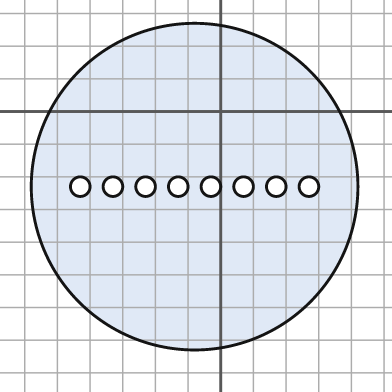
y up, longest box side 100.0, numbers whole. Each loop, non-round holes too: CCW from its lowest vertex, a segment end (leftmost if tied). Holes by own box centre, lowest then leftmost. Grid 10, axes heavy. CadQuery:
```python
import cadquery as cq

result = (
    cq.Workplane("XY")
    .moveTo(-8.0, -23.0)
    .circle(50.0)
    .moveTo(-43.0, -23.0)
    .circle(3.0)
    .moveTo(-33.0, -23.0)
    .circle(3.0)
    .moveTo(-23.0, -23.0)
    .circle(3.0)
    .moveTo(-13.0, -23.0)
    .circle(3.0)
    .moveTo(-3.0, -23.0)
    .circle(3.0)
    .moveTo(7.0, -23.0)
    .circle(3.0)
    .moveTo(17.0, -23.0)
    .circle(3.0)
    .moveTo(27.0, -23.0)
    .circle(3.0)
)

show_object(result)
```